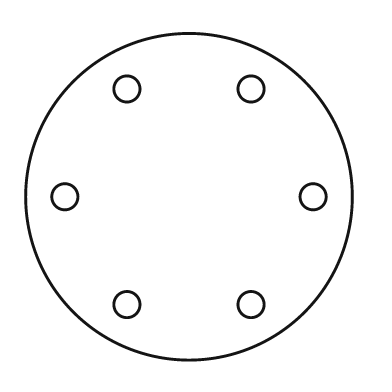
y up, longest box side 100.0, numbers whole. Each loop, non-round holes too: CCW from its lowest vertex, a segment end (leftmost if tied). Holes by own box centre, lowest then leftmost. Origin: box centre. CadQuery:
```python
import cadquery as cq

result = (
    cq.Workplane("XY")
    .moveTo(0.0, 0.0)
    .circle(50.0)
    .moveTo(-19.0, -33.0)
    .circle(4.0)
    .moveTo(19.0, -33.0)
    .circle(4.0)
    .moveTo(-38.0, 0.0)
    .circle(4.0)
    .moveTo(38.0, 0.0)
    .circle(4.0)
    .moveTo(-19.0, 33.0)
    .circle(4.0)
    .moveTo(19.0, 33.0)
    .circle(4.0)
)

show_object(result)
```